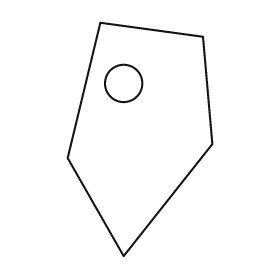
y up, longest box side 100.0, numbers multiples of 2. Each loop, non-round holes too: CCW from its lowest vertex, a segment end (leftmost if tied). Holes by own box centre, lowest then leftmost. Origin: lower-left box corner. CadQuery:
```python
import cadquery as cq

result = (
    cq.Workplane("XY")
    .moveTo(24.0, 0.0)
    .lineTo(62.0, 48.0)
    .lineTo(58.0, 94.0)
    .lineTo(14.0, 100.0)
    .lineTo(0.0, 42.0)
    .close()
    .moveTo(24.0, 74.0)
    .circle(8.0)
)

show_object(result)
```